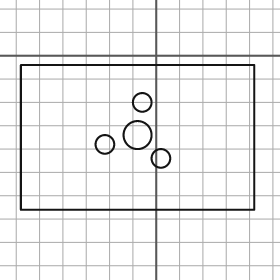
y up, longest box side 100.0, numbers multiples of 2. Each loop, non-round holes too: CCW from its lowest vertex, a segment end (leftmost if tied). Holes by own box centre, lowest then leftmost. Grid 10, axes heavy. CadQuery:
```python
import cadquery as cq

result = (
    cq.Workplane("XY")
    .moveTo(-58.0, -66.0)
    .lineTo(42.0, -66.0)
    .lineTo(42.0, -4.0)
    .lineTo(-58.0, -4.0)
    .close()
    .moveTo(2.0, -44.0)
    .circle(4.0)
    .moveTo(-22.0, -38.0)
    .circle(4.0)
    .moveTo(-8.0, -34.0)
    .circle(6.0)
    .moveTo(-6.0, -20.0)
    .circle(4.0)
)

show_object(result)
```